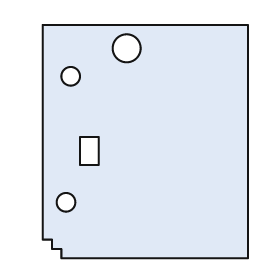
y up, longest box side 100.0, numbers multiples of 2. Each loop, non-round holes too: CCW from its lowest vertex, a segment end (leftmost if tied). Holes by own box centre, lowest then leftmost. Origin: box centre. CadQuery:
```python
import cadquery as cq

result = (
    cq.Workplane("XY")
    .moveTo(-36.0, -50.0)
    .lineTo(44.0, -50.0)
    .lineTo(44.0, 50.0)
    .lineTo(-44.0, 50.0)
    .lineTo(-44.0, -42.0)
    .lineTo(-40.0, -42.0)
    .lineTo(-40.0, -46.0)
    .lineTo(-36.0, -46.0)
    .close()
    .moveTo(-34.0, -26.0)
    .circle(4.0)
    .moveTo(-28.0, -10.0)
    .lineTo(-20.0, -10.0)
    .lineTo(-20.0, 2.0)
    .lineTo(-28.0, 2.0)
    .close()
    .moveTo(-32.0, 28.0)
    .circle(4.0)
    .moveTo(-8.0, 40.0)
    .circle(6.0)
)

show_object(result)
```